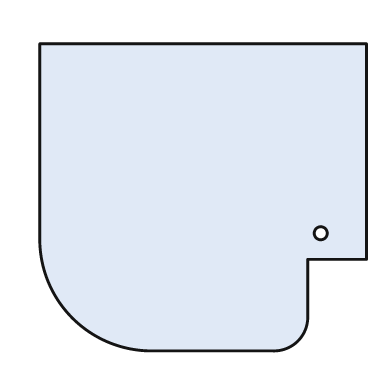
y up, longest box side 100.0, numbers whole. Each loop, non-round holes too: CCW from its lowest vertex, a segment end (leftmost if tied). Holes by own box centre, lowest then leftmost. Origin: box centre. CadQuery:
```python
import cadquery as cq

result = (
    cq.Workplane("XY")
    .moveTo(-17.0, -47.0)
    .lineTo(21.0, -47.0)
    .threePointArc((29.0, -44.0), (32.0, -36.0))
    .lineTo(32.0, -19.0)
    .lineTo(50.0, -19.0)
    .lineTo(50.0, 47.0)
    .lineTo(-50.0, 47.0)
    .lineTo(-50.0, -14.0)
    .threePointArc((-40.0, -37.0), (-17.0, -47.0))
    .close()
    .moveTo(36.0, -11.0)
    .circle(2.0)
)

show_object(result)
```